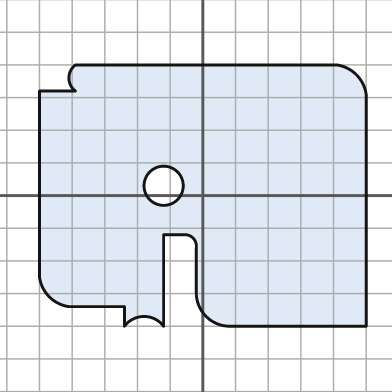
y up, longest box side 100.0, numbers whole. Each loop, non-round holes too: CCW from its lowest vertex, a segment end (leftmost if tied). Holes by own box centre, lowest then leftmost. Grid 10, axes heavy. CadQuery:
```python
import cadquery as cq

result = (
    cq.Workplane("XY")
    .moveTo(-24.0, -40.0)
    .threePointArc((-18.0, -37.0), (-12.0, -40.0))
    .lineTo(-12.0, -12.0)
    .lineTo(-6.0, -12.0)
    .threePointArc((-3.0, -13.0), (-2.0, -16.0))
    .lineTo(-2.0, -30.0)
    .threePointArc((1.0, -37.0), (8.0, -40.0))
    .lineTo(50.0, -40.0)
    .lineTo(50.0, 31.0)
    .threePointArc((47.0, 37.0), (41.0, 40.0))
    .lineTo(-39.0, 40.0)
    .threePointArc((-41.0, 36.0), (-39.0, 32.0))
    .lineTo(-50.0, 32.0)
    .lineTo(-50.0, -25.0)
    .threePointArc((-47.0, -31.0), (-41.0, -34.0))
    .lineTo(-24.0, -34.0)
    .close()
    .moveTo(-12.0, 3.0)
    .circle(6.0)
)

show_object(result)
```